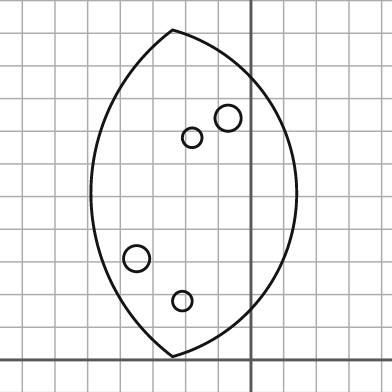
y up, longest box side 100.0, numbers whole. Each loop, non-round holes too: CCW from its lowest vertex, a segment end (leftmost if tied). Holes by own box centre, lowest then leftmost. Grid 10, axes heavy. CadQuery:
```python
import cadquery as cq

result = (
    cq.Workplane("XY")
    .moveTo(-24.0, 1.0)
    .threePointArc((14.0, 51.0), (-24.0, 101.0))
    .threePointArc((-49.0, 51.0), (-24.0, 1.0))
    .close()
    .moveTo(-21.0, 18.0)
    .circle(3.0)
    .moveTo(-35.0, 31.0)
    .circle(4.0)
    .moveTo(-18.0, 68.0)
    .circle(3.0)
    .moveTo(-7.0, 74.0)
    .circle(4.0)
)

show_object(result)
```